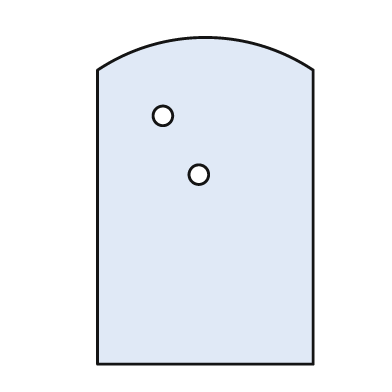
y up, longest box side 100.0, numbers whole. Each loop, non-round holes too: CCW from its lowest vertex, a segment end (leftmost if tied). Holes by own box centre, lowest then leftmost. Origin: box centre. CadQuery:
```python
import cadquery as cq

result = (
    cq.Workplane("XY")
    .moveTo(-33.0, -50.0)
    .lineTo(33.0, -50.0)
    .lineTo(33.0, 40.0)
    .threePointArc((0.0, 50.0), (-33.0, 40.0))
    .close()
    .moveTo(-2.0, 8.0)
    .circle(3.0)
    .moveTo(-13.0, 26.0)
    .circle(3.0)
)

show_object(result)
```